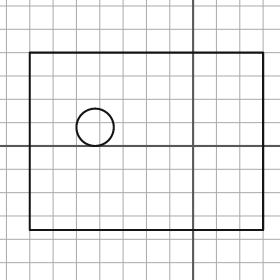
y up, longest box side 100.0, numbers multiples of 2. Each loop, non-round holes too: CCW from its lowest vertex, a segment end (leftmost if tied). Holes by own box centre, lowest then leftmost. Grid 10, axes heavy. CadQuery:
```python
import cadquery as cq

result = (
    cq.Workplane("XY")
    .moveTo(-70.0, -36.0)
    .lineTo(30.0, -36.0)
    .lineTo(30.0, 40.0)
    .lineTo(-70.0, 40.0)
    .close()
    .moveTo(-42.0, 8.0)
    .circle(8.0)
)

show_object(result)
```